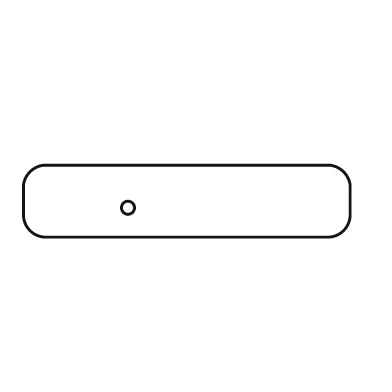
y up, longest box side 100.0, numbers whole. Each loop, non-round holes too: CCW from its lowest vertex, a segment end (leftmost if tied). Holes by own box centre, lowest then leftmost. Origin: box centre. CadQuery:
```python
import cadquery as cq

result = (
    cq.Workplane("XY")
    .moveTo(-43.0, -11.0)
    .lineTo(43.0, -11.0)
    .threePointArc((48.0, -9.0), (50.0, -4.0))
    .lineTo(50.0, 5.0)
    .threePointArc((48.0, 9.0), (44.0, 11.0))
    .lineTo(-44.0, 11.0)
    .threePointArc((-48.0, 9.0), (-50.0, 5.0))
    .lineTo(-50.0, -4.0)
    .threePointArc((-48.0, -9.0), (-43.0, -11.0))
    .close()
    .moveTo(-18.0, -2.0)
    .circle(2.0)
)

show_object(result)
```